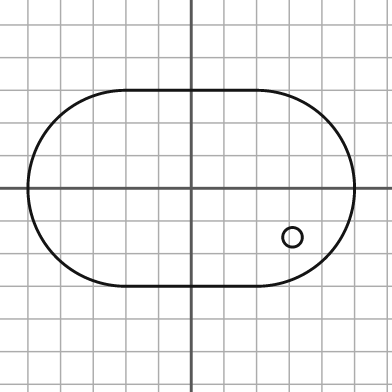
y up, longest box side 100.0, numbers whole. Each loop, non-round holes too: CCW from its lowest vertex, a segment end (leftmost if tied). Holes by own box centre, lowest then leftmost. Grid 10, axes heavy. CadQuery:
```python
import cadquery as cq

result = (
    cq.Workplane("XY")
    .moveTo(-20.0, -30.0)
    .lineTo(20.0, -30.0)
    .threePointArc((50.0, 0.0), (20.0, 30.0))
    .lineTo(-20.0, 30.0)
    .threePointArc((-50.0, 0.0), (-20.0, -30.0))
    .close()
    .moveTo(31.0, -15.0)
    .circle(3.0)
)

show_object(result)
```